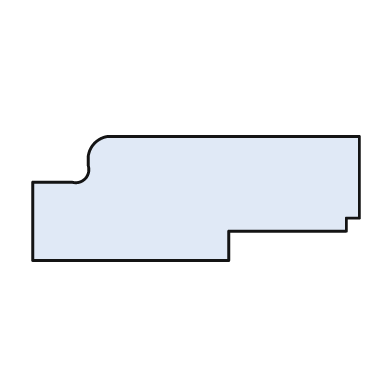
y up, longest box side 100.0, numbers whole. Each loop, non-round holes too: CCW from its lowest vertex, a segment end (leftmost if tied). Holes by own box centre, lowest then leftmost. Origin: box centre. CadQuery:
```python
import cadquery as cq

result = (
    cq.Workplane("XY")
    .moveTo(-50.0, -19.0)
    .lineTo(10.0, -19.0)
    .lineTo(10.0, -10.0)
    .lineTo(46.0, -10.0)
    .lineTo(46.0, -6.0)
    .lineTo(50.0, -6.0)
    .lineTo(50.0, 19.0)
    .lineTo(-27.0, 19.0)
    .threePointArc((-31.0, 17.0), (-33.0, 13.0))
    .lineTo(-33.0, 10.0)
    .threePointArc((-34.0, 6.0), (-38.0, 5.0))
    .lineTo(-50.0, 5.0)
    .close()
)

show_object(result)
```